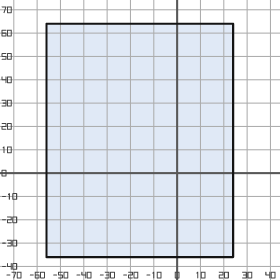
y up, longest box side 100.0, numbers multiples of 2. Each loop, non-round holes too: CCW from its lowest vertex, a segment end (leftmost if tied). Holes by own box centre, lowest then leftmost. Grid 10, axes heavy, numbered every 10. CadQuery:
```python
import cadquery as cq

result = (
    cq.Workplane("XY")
    .moveTo(-56.0, -36.0)
    .lineTo(24.0, -36.0)
    .lineTo(24.0, 64.0)
    .lineTo(-56.0, 64.0)
    .close()
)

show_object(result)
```